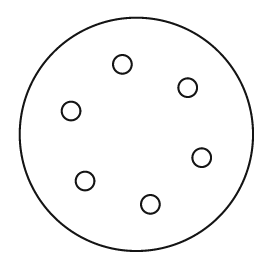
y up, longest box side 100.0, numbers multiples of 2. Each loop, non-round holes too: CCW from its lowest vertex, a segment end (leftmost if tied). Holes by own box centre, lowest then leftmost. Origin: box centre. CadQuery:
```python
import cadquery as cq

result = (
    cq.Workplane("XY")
    .moveTo(0.0, 0.0)
    .circle(50.0)
    .moveTo(6.0, -30.0)
    .circle(4.0)
    .moveTo(-22.0, -20.0)
    .circle(4.0)
    .moveTo(28.0, -10.0)
    .circle(4.0)
    .moveTo(-28.0, 10.0)
    .circle(4.0)
    .moveTo(22.0, 20.0)
    .circle(4.0)
    .moveTo(-6.0, 30.0)
    .circle(4.0)
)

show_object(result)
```